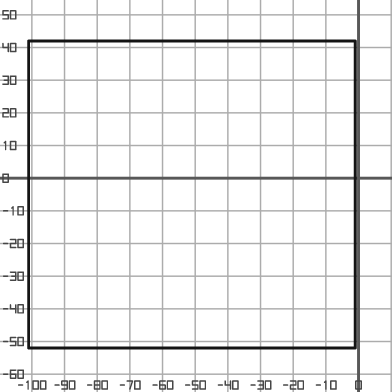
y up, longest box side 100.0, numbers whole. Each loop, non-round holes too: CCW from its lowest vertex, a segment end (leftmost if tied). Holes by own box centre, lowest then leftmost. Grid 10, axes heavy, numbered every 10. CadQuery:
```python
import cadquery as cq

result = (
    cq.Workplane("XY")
    .moveTo(-101.0, -52.0)
    .lineTo(-1.0, -52.0)
    .lineTo(-1.0, 42.0)
    .lineTo(-101.0, 42.0)
    .close()
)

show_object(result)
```